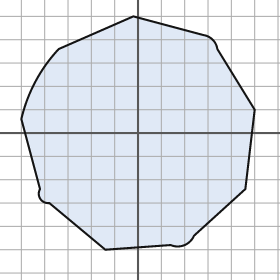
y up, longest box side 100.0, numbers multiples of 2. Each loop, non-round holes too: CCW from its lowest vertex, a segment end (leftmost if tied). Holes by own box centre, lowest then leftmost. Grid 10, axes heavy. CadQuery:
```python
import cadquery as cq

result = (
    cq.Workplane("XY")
    .moveTo(-14.0, -50.0)
    .lineTo(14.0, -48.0)
    .threePointArc((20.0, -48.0), (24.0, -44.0))
    .lineTo(46.0, -24.0)
    .lineTo(50.0, 10.0)
    .lineTo(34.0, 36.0)
    .threePointArc((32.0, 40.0), (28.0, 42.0))
    .lineTo(-2.0, 50.0)
    .lineTo(-34.0, 36.0)
    .threePointArc((-44.0, 22.0), (-50.0, 6.0))
    .lineTo(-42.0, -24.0)
    .threePointArc((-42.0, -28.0), (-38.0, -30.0))
    .close()
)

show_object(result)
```